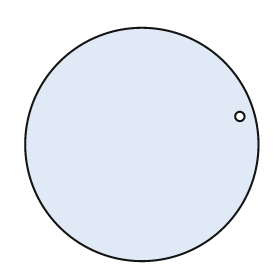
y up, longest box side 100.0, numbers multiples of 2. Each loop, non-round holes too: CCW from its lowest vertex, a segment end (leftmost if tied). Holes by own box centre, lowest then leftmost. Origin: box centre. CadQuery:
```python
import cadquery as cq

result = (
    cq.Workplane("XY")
    .moveTo(0.0, 0.0)
    .circle(50.0)
    .moveTo(42.0, 12.0)
    .circle(2.0)
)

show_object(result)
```